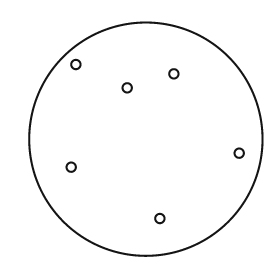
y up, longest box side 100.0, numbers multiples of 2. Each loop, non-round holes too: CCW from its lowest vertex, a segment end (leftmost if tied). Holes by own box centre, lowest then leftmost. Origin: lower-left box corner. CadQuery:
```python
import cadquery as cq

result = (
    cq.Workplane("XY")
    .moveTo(50.0, 50.0)
    .circle(50.0)
    .moveTo(56.0, 16.0)
    .circle(2.0)
    .moveTo(18.0, 38.0)
    .circle(2.0)
    .moveTo(90.0, 44.0)
    .circle(2.0)
    .moveTo(42.0, 72.0)
    .circle(2.0)
    .moveTo(62.0, 78.0)
    .circle(2.0)
    .moveTo(20.0, 82.0)
    .circle(2.0)
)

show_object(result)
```